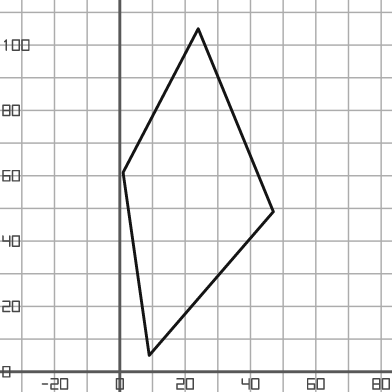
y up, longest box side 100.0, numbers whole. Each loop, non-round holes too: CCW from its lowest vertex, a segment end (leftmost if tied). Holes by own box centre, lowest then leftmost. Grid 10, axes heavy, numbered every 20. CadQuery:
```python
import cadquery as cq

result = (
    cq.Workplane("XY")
    .moveTo(9.0, 5.0)
    .lineTo(47.0, 49.0)
    .lineTo(24.0, 105.0)
    .lineTo(1.0, 61.0)
    .close()
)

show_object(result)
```